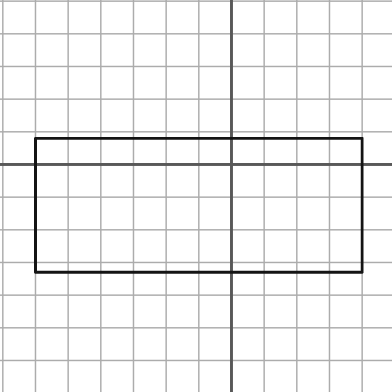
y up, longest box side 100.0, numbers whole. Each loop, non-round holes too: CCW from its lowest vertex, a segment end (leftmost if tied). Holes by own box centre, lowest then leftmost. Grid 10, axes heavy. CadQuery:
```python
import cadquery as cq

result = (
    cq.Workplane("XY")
    .moveTo(-60.0, -33.0)
    .lineTo(40.0, -33.0)
    .lineTo(40.0, 8.0)
    .lineTo(-60.0, 8.0)
    .close()
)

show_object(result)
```